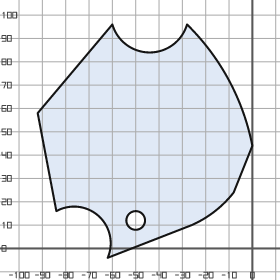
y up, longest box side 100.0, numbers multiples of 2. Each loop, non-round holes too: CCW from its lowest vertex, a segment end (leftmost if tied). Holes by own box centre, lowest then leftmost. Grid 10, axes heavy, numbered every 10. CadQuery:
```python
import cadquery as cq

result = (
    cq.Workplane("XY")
    .moveTo(-62.0, -4.0)
    .lineTo(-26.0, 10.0)
    .threePointArc((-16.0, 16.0), (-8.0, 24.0))
    .lineTo(0.0, 44.0)
    .threePointArc((-10.0, 72.0), (-28.0, 96.0))
    .threePointArc((-44.0, 84.0), (-60.0, 96.0))
    .lineTo(-92.0, 58.0)
    .lineTo(-84.0, 16.0)
    .threePointArc((-66.0, 14.0), (-62.0, -4.0))
    .close()
    .moveTo(-50.0, 12.0)
    .circle(4.0)
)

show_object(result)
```